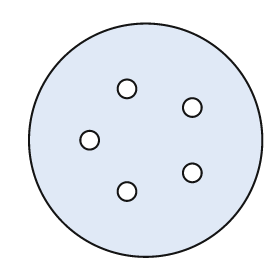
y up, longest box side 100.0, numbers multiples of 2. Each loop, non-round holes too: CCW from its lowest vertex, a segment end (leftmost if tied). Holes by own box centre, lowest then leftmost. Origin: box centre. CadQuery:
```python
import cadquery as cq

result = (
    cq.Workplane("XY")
    .moveTo(0.0, 0.0)
    .circle(50.0)
    .moveTo(-8.0, -22.0)
    .circle(4.0)
    .moveTo(20.0, -14.0)
    .circle(4.0)
    .moveTo(-24.0, 0.0)
    .circle(4.0)
    .moveTo(20.0, 14.0)
    .circle(4.0)
    .moveTo(-8.0, 22.0)
    .circle(4.0)
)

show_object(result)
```